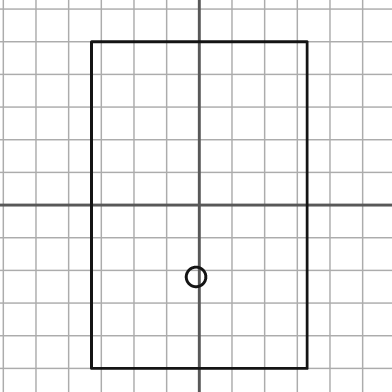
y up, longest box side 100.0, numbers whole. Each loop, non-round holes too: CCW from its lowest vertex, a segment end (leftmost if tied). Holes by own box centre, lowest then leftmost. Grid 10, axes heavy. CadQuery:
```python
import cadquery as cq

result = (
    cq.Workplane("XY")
    .moveTo(-33.0, -50.0)
    .lineTo(33.0, -50.0)
    .lineTo(33.0, 50.0)
    .lineTo(-33.0, 50.0)
    .close()
    .moveTo(-1.0, -22.0)
    .circle(3.0)
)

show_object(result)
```